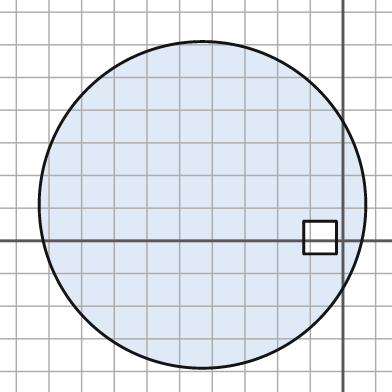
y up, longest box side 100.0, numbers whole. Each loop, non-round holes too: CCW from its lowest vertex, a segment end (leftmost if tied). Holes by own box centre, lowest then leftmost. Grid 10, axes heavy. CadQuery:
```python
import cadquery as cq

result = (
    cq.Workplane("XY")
    .moveTo(-43.0, 11.0)
    .circle(50.0)
    .moveTo(-12.0, -4.0)
    .lineTo(-2.0, -4.0)
    .lineTo(-2.0, 6.0)
    .lineTo(-12.0, 6.0)
    .close()
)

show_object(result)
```